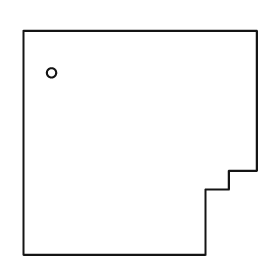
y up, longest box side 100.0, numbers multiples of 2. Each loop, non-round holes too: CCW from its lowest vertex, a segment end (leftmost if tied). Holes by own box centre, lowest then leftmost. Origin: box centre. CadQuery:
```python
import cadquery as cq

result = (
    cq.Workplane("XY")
    .moveTo(-50.0, -48.0)
    .lineTo(28.0, -48.0)
    .lineTo(28.0, -20.0)
    .lineTo(38.0, -20.0)
    .lineTo(38.0, -12.0)
    .lineTo(50.0, -12.0)
    .lineTo(50.0, 48.0)
    .lineTo(-50.0, 48.0)
    .close()
    .moveTo(-38.0, 30.0)
    .circle(2.0)
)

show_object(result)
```